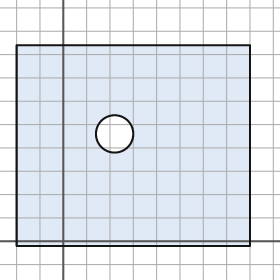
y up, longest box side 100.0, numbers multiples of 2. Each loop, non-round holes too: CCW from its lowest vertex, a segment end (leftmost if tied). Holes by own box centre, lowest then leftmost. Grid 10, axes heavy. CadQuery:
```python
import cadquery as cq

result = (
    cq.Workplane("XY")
    .moveTo(-20.0, -2.0)
    .lineTo(80.0, -2.0)
    .lineTo(80.0, 84.0)
    .lineTo(-20.0, 84.0)
    .close()
    .moveTo(22.0, 46.0)
    .circle(8.0)
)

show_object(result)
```